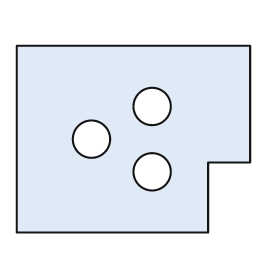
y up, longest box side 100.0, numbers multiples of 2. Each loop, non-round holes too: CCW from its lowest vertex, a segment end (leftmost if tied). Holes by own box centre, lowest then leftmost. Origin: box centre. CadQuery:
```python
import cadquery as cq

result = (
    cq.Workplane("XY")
    .moveTo(-50.0, -40.0)
    .lineTo(32.0, -40.0)
    .lineTo(32.0, -10.0)
    .lineTo(50.0, -10.0)
    .lineTo(50.0, 40.0)
    .lineTo(-50.0, 40.0)
    .close()
    .moveTo(8.0, -14.0)
    .circle(8.0)
    .moveTo(-18.0, 0.0)
    .circle(8.0)
    .moveTo(8.0, 14.0)
    .circle(8.0)
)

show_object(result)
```